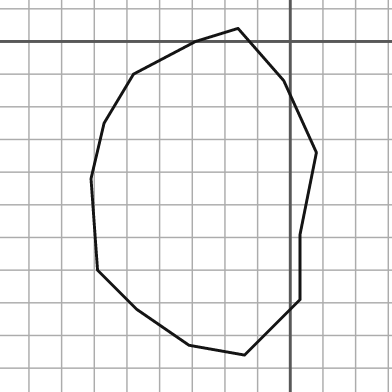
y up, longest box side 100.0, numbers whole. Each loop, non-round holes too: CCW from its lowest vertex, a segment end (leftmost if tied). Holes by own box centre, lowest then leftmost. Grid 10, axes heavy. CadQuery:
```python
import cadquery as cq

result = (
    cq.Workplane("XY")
    .moveTo(-14.0, -96.0)
    .lineTo(3.0, -79.0)
    .lineTo(3.0, -59.0)
    .lineTo(8.0, -34.0)
    .lineTo(-2.0, -12.0)
    .lineTo(-16.0, 4.0)
    .lineTo(-29.0, 0.0)
    .lineTo(-48.0, -10.0)
    .lineTo(-57.0, -25.0)
    .lineTo(-61.0, -42.0)
    .lineTo(-59.0, -70.0)
    .lineTo(-47.0, -82.0)
    .lineTo(-31.0, -93.0)
    .close()
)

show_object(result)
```